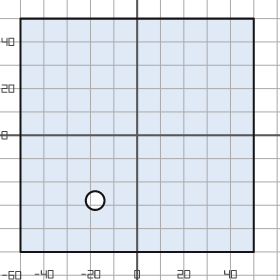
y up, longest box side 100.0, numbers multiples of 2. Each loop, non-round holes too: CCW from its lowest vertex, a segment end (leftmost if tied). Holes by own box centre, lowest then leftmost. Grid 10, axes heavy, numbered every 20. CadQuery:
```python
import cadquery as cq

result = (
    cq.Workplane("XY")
    .moveTo(-50.0, -50.0)
    .lineTo(50.0, -50.0)
    .lineTo(50.0, 50.0)
    .lineTo(-50.0, 50.0)
    .close()
    .moveTo(-18.0, -28.0)
    .circle(4.0)
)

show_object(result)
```